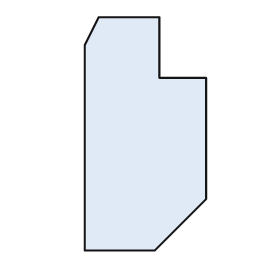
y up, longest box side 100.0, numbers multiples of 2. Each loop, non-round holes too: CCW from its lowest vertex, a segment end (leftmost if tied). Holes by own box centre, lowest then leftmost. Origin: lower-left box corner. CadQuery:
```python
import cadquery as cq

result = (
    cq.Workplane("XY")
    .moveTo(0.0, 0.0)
    .lineTo(30.0, 0.0)
    .lineTo(52.0, 22.0)
    .lineTo(52.0, 74.0)
    .lineTo(32.0, 74.0)
    .lineTo(32.0, 100.0)
    .lineTo(6.0, 100.0)
    .lineTo(0.0, 88.0)
    .close()
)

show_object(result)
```